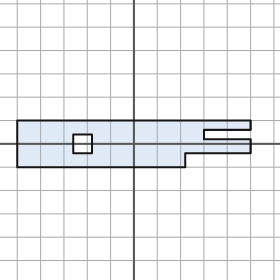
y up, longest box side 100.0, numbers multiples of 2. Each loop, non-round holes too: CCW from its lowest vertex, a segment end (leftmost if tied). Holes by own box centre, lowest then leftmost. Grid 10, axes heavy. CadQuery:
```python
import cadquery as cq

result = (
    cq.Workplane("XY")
    .moveTo(-50.0, -10.0)
    .lineTo(22.0, -10.0)
    .lineTo(22.0, -4.0)
    .lineTo(50.0, -4.0)
    .lineTo(50.0, 2.0)
    .lineTo(30.0, 2.0)
    .lineTo(30.0, 6.0)
    .lineTo(50.0, 6.0)
    .lineTo(50.0, 10.0)
    .lineTo(-50.0, 10.0)
    .close()
    .moveTo(-26.0, -4.0)
    .lineTo(-18.0, -4.0)
    .lineTo(-18.0, 4.0)
    .lineTo(-26.0, 4.0)
    .close()
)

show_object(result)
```